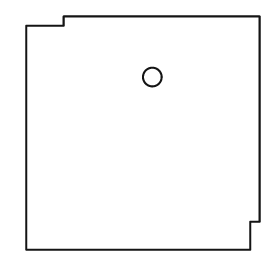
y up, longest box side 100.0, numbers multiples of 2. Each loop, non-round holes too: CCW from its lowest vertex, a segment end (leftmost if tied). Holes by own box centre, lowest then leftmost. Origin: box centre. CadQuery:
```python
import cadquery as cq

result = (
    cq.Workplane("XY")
    .moveTo(-50.0, -50.0)
    .lineTo(46.0, -50.0)
    .lineTo(46.0, -38.0)
    .lineTo(50.0, -38.0)
    .lineTo(50.0, 50.0)
    .lineTo(-34.0, 50.0)
    .lineTo(-34.0, 46.0)
    .lineTo(-50.0, 46.0)
    .close()
    .moveTo(4.0, 24.0)
    .circle(4.0)
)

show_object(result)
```